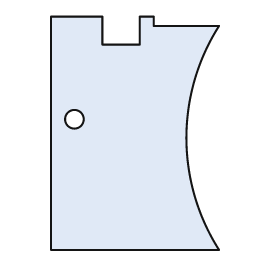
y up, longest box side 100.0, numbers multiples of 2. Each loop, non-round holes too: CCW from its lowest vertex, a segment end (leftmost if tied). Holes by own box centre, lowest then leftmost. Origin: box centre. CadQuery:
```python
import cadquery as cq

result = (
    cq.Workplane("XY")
    .moveTo(-36.0, -50.0)
    .lineTo(36.0, -50.0)
    .threePointArc((22.0, -2.0), (36.0, 46.0))
    .lineTo(8.0, 46.0)
    .lineTo(8.0, 50.0)
    .lineTo(2.0, 50.0)
    .lineTo(2.0, 38.0)
    .lineTo(-14.0, 38.0)
    .lineTo(-14.0, 50.0)
    .lineTo(-36.0, 50.0)
    .close()
    .moveTo(-26.0, 6.0)
    .circle(4.0)
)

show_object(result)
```